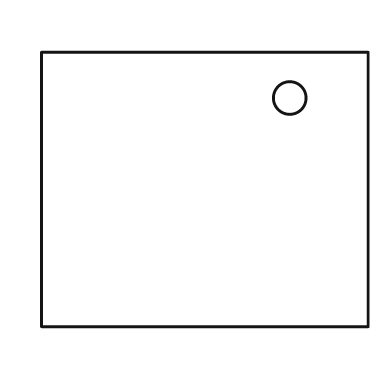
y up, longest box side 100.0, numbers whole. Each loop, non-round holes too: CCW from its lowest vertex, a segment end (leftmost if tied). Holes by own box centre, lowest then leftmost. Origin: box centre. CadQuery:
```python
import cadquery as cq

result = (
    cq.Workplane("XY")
    .moveTo(-50.0, -42.0)
    .lineTo(50.0, -42.0)
    .lineTo(50.0, 42.0)
    .lineTo(-50.0, 42.0)
    .close()
    .moveTo(26.0, 28.0)
    .circle(5.0)
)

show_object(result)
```